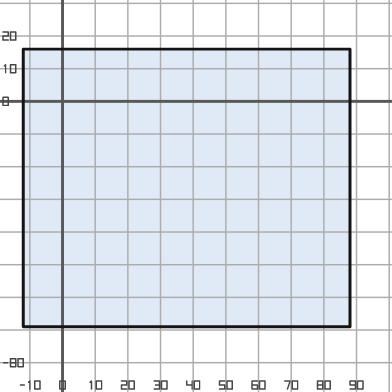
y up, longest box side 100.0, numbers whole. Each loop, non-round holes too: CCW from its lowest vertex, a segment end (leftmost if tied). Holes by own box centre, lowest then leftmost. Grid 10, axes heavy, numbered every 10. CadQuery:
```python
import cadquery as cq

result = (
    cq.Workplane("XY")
    .moveTo(-12.0, -69.0)
    .lineTo(88.0, -69.0)
    .lineTo(88.0, 16.0)
    .lineTo(-12.0, 16.0)
    .close()
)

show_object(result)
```